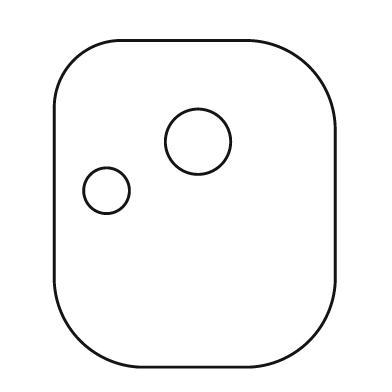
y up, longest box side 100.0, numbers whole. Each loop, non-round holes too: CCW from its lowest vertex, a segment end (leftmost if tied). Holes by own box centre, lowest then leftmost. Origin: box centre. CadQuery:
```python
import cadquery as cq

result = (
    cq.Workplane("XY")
    .moveTo(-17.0, -50.0)
    .lineTo(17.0, -50.0)
    .threePointArc((35.0, -42.0), (43.0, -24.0))
    .lineTo(43.0, 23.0)
    .threePointArc((35.0, 42.0), (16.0, 50.0))
    .lineTo(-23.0, 50.0)
    .threePointArc((-37.0, 44.0), (-43.0, 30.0))
    .lineTo(-43.0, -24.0)
    .threePointArc((-35.0, -42.0), (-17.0, -50.0))
    .close()
    .moveTo(-27.0, 4.0)
    .circle(7.0)
    .moveTo(1.0, 19.0)
    .circle(10.0)
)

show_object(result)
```